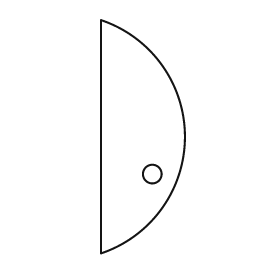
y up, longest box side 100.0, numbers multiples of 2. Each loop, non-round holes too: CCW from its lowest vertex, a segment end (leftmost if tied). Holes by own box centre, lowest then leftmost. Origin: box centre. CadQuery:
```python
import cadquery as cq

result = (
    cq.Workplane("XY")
    .moveTo(-18.0, -50.0)
    .threePointArc((18.0, 0.0), (-18.0, 50.0))
    .close()
    .moveTo(4.0, -16.0)
    .circle(4.0)
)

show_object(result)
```